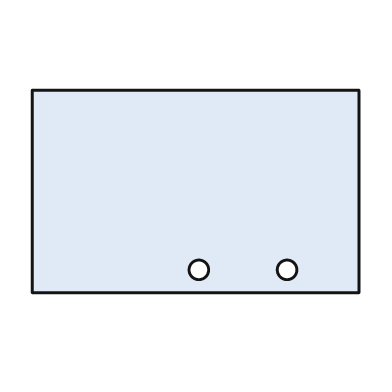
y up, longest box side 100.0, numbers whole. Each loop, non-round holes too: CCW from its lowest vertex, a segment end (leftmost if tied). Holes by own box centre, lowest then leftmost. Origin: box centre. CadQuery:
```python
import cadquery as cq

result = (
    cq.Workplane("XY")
    .moveTo(-50.0, -31.0)
    .lineTo(50.0, -31.0)
    .lineTo(50.0, 31.0)
    .lineTo(-50.0, 31.0)
    .close()
    .moveTo(1.0, -24.0)
    .circle(3.0)
    .moveTo(28.0, -24.0)
    .circle(3.0)
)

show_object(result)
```